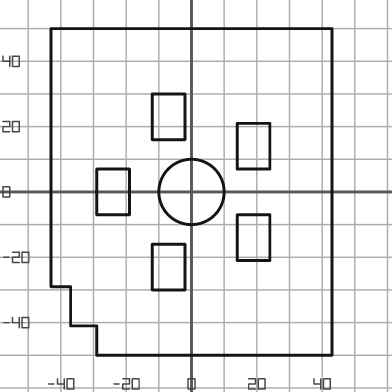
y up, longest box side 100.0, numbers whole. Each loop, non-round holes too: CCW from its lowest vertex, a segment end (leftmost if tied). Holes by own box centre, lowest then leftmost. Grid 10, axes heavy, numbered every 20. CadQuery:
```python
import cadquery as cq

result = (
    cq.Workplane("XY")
    .moveTo(-29.0, -50.0)
    .lineTo(43.0, -50.0)
    .lineTo(43.0, 50.0)
    .lineTo(-43.0, 50.0)
    .lineTo(-43.0, -29.0)
    .lineTo(-37.0, -29.0)
    .lineTo(-37.0, -41.0)
    .lineTo(-29.0, -41.0)
    .close()
    .moveTo(-12.0, -30.0)
    .lineTo(-2.0, -30.0)
    .lineTo(-2.0, -16.0)
    .lineTo(-12.0, -16.0)
    .close()
    .moveTo(14.0, -21.0)
    .lineTo(24.0, -21.0)
    .lineTo(24.0, -7.0)
    .lineTo(14.0, -7.0)
    .close()
    .moveTo(-29.0, -7.0)
    .lineTo(-19.0, -7.0)
    .lineTo(-19.0, 7.0)
    .lineTo(-29.0, 7.0)
    .close()
    .moveTo(0.0, 0.0)
    .circle(10.0)
    .moveTo(14.0, 7.0)
    .lineTo(24.0, 7.0)
    .lineTo(24.0, 21.0)
    .lineTo(14.0, 21.0)
    .close()
    .moveTo(-12.0, 16.0)
    .lineTo(-2.0, 16.0)
    .lineTo(-2.0, 30.0)
    .lineTo(-12.0, 30.0)
    .close()
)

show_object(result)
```